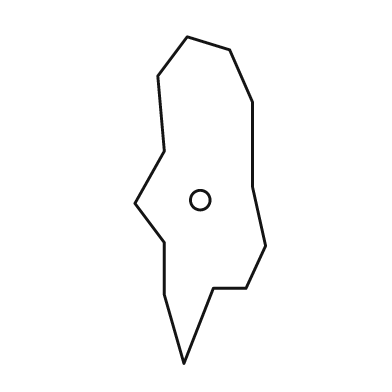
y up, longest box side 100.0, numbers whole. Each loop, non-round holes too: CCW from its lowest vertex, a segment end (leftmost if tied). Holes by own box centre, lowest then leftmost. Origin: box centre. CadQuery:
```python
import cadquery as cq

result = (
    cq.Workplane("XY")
    .moveTo(-5.0, -50.0)
    .lineTo(4.0, -27.0)
    .lineTo(14.0, -27.0)
    .lineTo(20.0, -14.0)
    .lineTo(16.0, 4.0)
    .lineTo(16.0, 30.0)
    .lineTo(9.0, 46.0)
    .lineTo(-4.0, 50.0)
    .lineTo(-13.0, 38.0)
    .lineTo(-11.0, 15.0)
    .lineTo(-20.0, -1.0)
    .lineTo(-11.0, -13.0)
    .lineTo(-11.0, -29.0)
    .close()
    .moveTo(0.0, 0.0)
    .circle(3.0)
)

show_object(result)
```